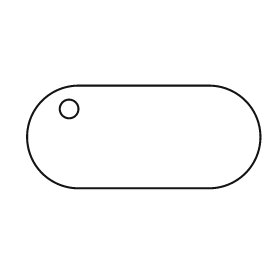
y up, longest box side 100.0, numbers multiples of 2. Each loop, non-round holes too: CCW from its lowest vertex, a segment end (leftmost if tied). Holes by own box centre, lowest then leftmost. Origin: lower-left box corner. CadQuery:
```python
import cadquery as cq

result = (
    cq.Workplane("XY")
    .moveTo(22.0, 0.0)
    .lineTo(78.0, 0.0)
    .threePointArc((100.0, 22.0), (78.0, 44.0))
    .lineTo(22.0, 44.0)
    .threePointArc((0.0, 22.0), (22.0, 0.0))
    .close()
    .moveTo(18.0, 34.0)
    .circle(4.0)
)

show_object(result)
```